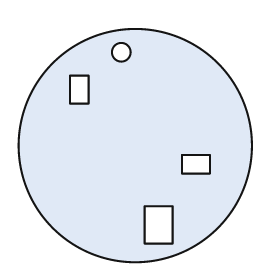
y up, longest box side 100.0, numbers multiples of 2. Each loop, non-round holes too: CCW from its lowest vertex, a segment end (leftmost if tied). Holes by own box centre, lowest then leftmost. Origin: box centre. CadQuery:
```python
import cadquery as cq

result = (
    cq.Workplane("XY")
    .moveTo(0.0, 0.0)
    .circle(50.0)
    .moveTo(4.0, -42.0)
    .lineTo(16.0, -42.0)
    .lineTo(16.0, -26.0)
    .lineTo(4.0, -26.0)
    .close()
    .moveTo(20.0, -12.0)
    .lineTo(32.0, -12.0)
    .lineTo(32.0, -4.0)
    .lineTo(20.0, -4.0)
    .close()
    .moveTo(-28.0, 18.0)
    .lineTo(-20.0, 18.0)
    .lineTo(-20.0, 30.0)
    .lineTo(-28.0, 30.0)
    .close()
    .moveTo(-6.0, 40.0)
    .circle(4.0)
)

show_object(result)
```